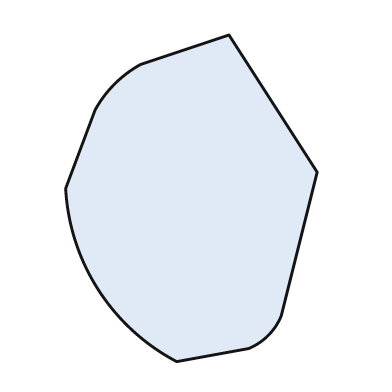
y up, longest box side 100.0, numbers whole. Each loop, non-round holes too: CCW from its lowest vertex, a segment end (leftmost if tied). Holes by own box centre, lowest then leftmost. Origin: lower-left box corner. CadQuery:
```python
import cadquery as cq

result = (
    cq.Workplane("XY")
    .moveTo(34.0, 0.0)
    .lineTo(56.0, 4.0)
    .threePointArc((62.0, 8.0), (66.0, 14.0))
    .lineTo(77.0, 58.0)
    .lineTo(50.0, 100.0)
    .lineTo(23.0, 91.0)
    .threePointArc((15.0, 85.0), (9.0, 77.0))
    .lineTo(0.0, 53.0)
    .threePointArc((10.0, 22.0), (34.0, 0.0))
    .close()
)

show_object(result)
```